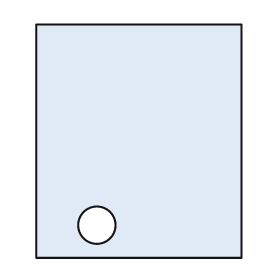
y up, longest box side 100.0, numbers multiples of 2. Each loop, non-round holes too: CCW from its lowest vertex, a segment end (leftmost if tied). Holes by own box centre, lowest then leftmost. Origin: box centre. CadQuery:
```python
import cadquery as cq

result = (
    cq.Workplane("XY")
    .moveTo(-44.0, -50.0)
    .lineTo(44.0, -50.0)
    .lineTo(44.0, 50.0)
    .lineTo(-44.0, 50.0)
    .close()
    .moveTo(-18.0, -36.0)
    .circle(8.0)
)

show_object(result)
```